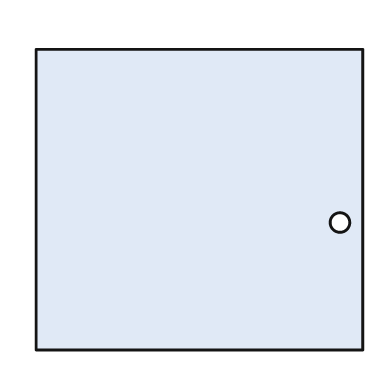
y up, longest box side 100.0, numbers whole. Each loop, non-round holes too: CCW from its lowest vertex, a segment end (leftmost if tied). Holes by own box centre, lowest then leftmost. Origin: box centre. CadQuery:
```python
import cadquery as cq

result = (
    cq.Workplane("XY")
    .moveTo(-50.0, -46.0)
    .lineTo(50.0, -46.0)
    .lineTo(50.0, 46.0)
    .lineTo(-50.0, 46.0)
    .close()
    .moveTo(43.0, -7.0)
    .circle(3.0)
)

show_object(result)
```